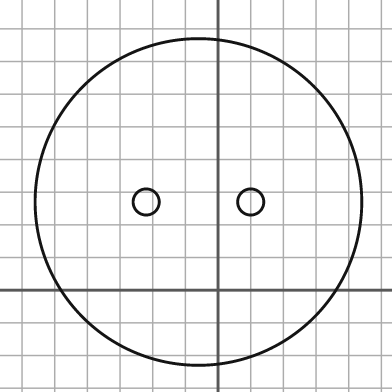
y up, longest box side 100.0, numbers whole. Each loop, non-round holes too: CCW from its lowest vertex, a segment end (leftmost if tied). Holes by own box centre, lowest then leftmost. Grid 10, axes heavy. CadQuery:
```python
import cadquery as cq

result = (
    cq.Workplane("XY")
    .moveTo(-6.0, 27.0)
    .circle(50.0)
    .moveTo(-22.0, 27.0)
    .circle(4.0)
    .moveTo(10.0, 27.0)
    .circle(4.0)
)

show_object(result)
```